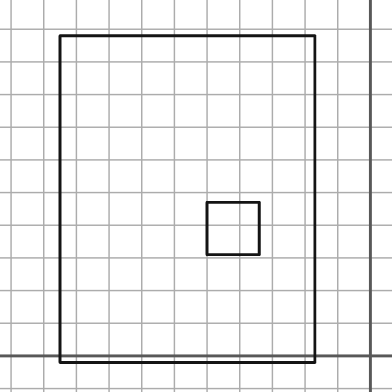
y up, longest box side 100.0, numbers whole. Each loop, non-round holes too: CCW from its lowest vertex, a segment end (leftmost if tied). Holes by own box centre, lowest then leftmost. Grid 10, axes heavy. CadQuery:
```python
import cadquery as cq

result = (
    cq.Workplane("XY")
    .moveTo(-95.0, -2.0)
    .lineTo(-17.0, -2.0)
    .lineTo(-17.0, 98.0)
    .lineTo(-95.0, 98.0)
    .close()
    .moveTo(-50.0, 31.0)
    .lineTo(-34.0, 31.0)
    .lineTo(-34.0, 47.0)
    .lineTo(-50.0, 47.0)
    .close()
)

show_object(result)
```